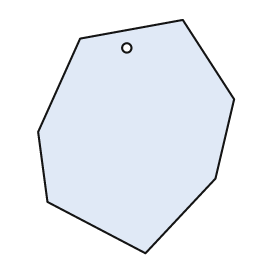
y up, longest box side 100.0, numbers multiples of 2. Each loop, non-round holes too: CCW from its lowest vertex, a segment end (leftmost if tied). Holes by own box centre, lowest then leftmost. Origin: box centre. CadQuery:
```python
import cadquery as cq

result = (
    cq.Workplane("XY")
    .moveTo(4.0, -50.0)
    .lineTo(34.0, -18.0)
    .lineTo(42.0, 16.0)
    .lineTo(20.0, 50.0)
    .lineTo(-24.0, 42.0)
    .lineTo(-42.0, 2.0)
    .lineTo(-38.0, -28.0)
    .close()
    .moveTo(-4.0, 38.0)
    .circle(2.0)
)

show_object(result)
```